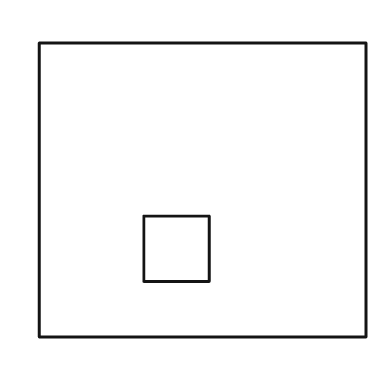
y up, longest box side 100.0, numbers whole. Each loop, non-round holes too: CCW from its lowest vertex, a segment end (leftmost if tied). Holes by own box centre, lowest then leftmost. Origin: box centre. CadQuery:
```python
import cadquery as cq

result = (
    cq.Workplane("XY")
    .moveTo(-50.0, -45.0)
    .lineTo(50.0, -45.0)
    .lineTo(50.0, 45.0)
    .lineTo(-50.0, 45.0)
    .close()
    .moveTo(-18.0, -28.0)
    .lineTo(2.0, -28.0)
    .lineTo(2.0, -8.0)
    .lineTo(-18.0, -8.0)
    .close()
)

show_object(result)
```